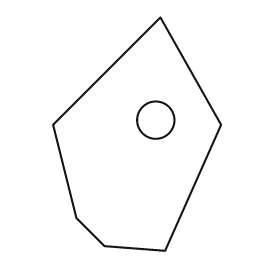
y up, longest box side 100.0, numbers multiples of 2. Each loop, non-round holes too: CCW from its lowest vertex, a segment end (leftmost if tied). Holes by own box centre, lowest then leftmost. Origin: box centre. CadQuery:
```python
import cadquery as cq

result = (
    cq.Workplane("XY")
    .moveTo(12.0, -50.0)
    .lineTo(36.0, 4.0)
    .lineTo(10.0, 50.0)
    .lineTo(-36.0, 4.0)
    .lineTo(-26.0, -36.0)
    .lineTo(-14.0, -48.0)
    .close()
    .moveTo(8.0, 6.0)
    .circle(8.0)
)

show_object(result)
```